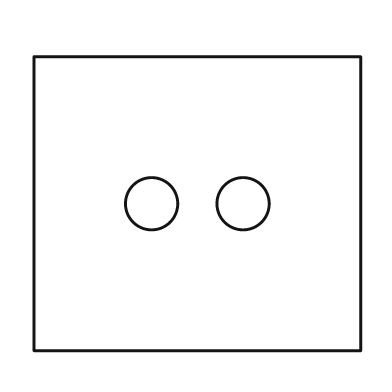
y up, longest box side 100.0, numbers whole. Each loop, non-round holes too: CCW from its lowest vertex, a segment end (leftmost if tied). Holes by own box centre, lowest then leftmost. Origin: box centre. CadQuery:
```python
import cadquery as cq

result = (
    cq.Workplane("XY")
    .moveTo(-50.0, -45.0)
    .lineTo(50.0, -45.0)
    .lineTo(50.0, 45.0)
    .lineTo(-50.0, 45.0)
    .close()
    .moveTo(-14.0, 0.0)
    .circle(8.0)
    .moveTo(14.0, 0.0)
    .circle(8.0)
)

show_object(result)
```